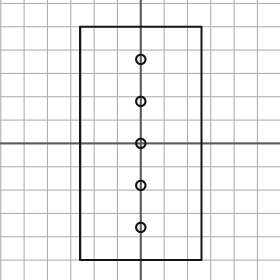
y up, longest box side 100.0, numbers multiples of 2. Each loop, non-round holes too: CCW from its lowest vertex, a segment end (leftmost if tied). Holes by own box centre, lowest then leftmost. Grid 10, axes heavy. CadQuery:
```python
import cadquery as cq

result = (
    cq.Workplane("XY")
    .moveTo(-26.0, -50.0)
    .lineTo(26.0, -50.0)
    .lineTo(26.0, 50.0)
    .lineTo(-26.0, 50.0)
    .close()
    .moveTo(0.0, -36.0)
    .circle(2.0)
    .moveTo(0.0, -18.0)
    .circle(2.0)
    .moveTo(0.0, 0.0)
    .circle(2.0)
    .moveTo(0.0, 18.0)
    .circle(2.0)
    .moveTo(0.0, 36.0)
    .circle(2.0)
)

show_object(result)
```